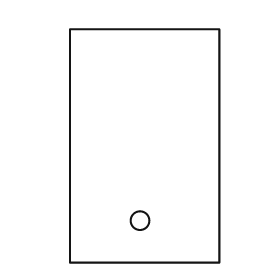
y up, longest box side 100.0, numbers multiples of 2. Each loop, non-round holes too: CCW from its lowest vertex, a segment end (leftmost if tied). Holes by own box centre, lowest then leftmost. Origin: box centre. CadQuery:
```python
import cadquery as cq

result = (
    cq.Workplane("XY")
    .moveTo(-32.0, -50.0)
    .lineTo(32.0, -50.0)
    .lineTo(32.0, 50.0)
    .lineTo(-32.0, 50.0)
    .close()
    .moveTo(-2.0, -32.0)
    .circle(4.0)
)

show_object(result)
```